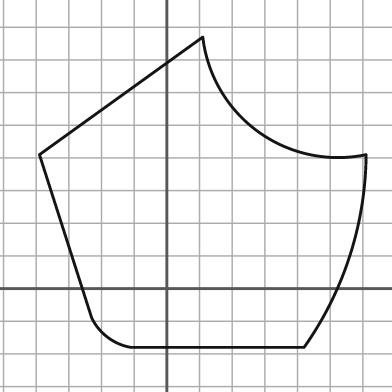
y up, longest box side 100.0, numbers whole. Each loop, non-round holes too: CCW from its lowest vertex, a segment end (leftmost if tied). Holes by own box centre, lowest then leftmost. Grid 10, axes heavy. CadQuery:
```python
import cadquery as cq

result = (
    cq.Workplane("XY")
    .moveTo(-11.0, -18.0)
    .lineTo(42.0, -18.0)
    .threePointArc((56.0, 10.0), (61.0, 41.0))
    .threePointArc((28.0, 48.0), (11.0, 77.0))
    .lineTo(-39.0, 41.0)
    .lineTo(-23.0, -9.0)
    .threePointArc((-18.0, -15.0), (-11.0, -18.0))
    .close()
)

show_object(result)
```